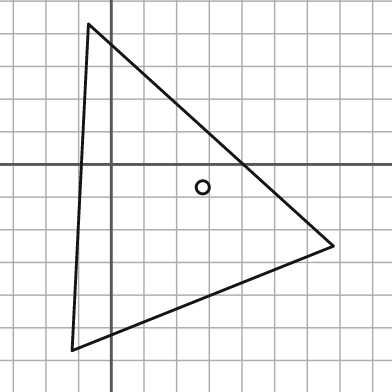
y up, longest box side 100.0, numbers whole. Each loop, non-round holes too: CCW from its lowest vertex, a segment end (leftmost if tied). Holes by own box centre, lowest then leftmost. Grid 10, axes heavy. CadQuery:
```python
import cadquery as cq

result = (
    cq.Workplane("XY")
    .moveTo(-12.0, -57.0)
    .lineTo(68.0, -25.0)
    .lineTo(-7.0, 43.0)
    .close()
    .moveTo(28.0, -7.0)
    .circle(2.0)
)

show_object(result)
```